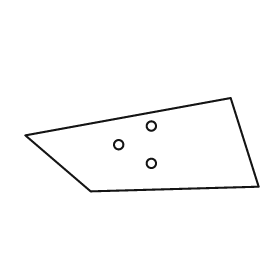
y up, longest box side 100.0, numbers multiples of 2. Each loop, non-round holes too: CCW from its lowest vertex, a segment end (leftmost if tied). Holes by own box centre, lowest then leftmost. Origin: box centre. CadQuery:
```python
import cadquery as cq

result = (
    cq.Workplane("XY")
    .moveTo(-22.0, -20.0)
    .lineTo(50.0, -18.0)
    .lineTo(38.0, 20.0)
    .lineTo(-50.0, 4.0)
    .close()
    .moveTo(4.0, -8.0)
    .circle(2.0)
    .moveTo(-10.0, 0.0)
    .circle(2.0)
    .moveTo(4.0, 8.0)
    .circle(2.0)
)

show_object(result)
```